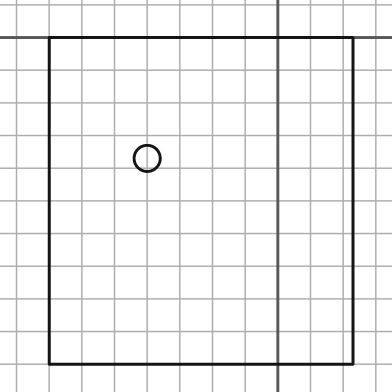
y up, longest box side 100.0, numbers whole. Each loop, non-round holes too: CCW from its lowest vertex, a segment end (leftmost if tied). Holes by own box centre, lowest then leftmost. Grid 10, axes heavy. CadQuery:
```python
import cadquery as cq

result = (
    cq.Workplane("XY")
    .moveTo(-70.0, -100.0)
    .lineTo(23.0, -100.0)
    .lineTo(23.0, 0.0)
    .lineTo(-70.0, 0.0)
    .close()
    .moveTo(-40.0, -37.0)
    .circle(4.0)
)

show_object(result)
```